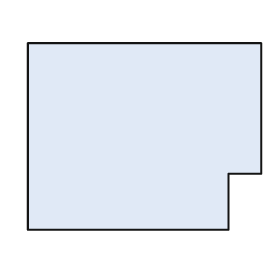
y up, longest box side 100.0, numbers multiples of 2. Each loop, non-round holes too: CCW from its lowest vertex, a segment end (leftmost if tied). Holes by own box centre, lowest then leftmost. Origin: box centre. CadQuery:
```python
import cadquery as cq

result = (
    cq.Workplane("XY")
    .moveTo(-50.0, -40.0)
    .lineTo(36.0, -40.0)
    .lineTo(36.0, -16.0)
    .lineTo(50.0, -16.0)
    .lineTo(50.0, 40.0)
    .lineTo(-50.0, 40.0)
    .close()
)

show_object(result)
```